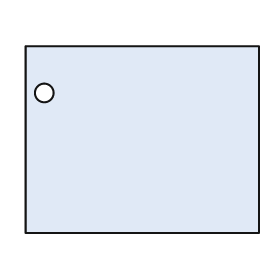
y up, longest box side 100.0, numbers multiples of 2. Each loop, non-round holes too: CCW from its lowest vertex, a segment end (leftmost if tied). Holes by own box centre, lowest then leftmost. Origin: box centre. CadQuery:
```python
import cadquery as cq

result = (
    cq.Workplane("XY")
    .moveTo(-50.0, -40.0)
    .lineTo(50.0, -40.0)
    .lineTo(50.0, 40.0)
    .lineTo(-50.0, 40.0)
    .close()
    .moveTo(-42.0, 20.0)
    .circle(4.0)
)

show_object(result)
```